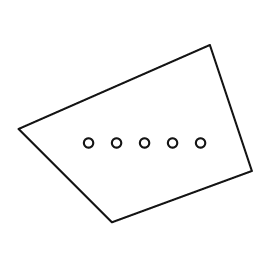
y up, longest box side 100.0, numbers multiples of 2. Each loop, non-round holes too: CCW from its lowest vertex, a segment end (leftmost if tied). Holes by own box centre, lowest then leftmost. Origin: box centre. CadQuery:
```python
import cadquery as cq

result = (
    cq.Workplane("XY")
    .moveTo(-10.0, -38.0)
    .lineTo(50.0, -16.0)
    .lineTo(32.0, 38.0)
    .lineTo(-50.0, 2.0)
    .close()
    .moveTo(-20.0, -4.0)
    .circle(2.0)
    .moveTo(-8.0, -4.0)
    .circle(2.0)
    .moveTo(4.0, -4.0)
    .circle(2.0)
    .moveTo(16.0, -4.0)
    .circle(2.0)
    .moveTo(28.0, -4.0)
    .circle(2.0)
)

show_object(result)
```